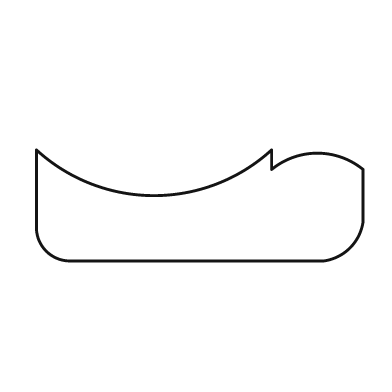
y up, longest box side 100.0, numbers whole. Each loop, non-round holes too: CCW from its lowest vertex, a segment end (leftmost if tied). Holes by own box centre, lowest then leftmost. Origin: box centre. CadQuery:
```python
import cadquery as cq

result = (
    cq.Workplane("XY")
    .moveTo(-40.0, -17.0)
    .lineTo(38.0, -17.0)
    .threePointArc((46.0, -13.0), (50.0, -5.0))
    .lineTo(50.0, 11.0)
    .threePointArc((36.0, 16.0), (22.0, 11.0))
    .lineTo(22.0, 17.0)
    .threePointArc((-14.0, 3.0), (-50.0, 17.0))
    .lineTo(-50.0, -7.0)
    .threePointArc((-47.0, -14.0), (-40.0, -17.0))
    .close()
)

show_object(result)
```